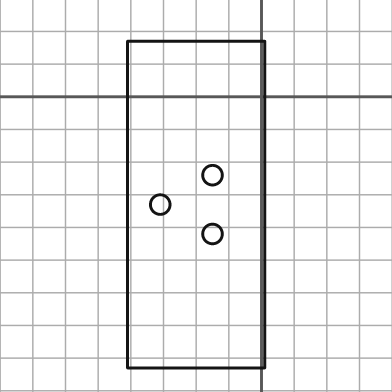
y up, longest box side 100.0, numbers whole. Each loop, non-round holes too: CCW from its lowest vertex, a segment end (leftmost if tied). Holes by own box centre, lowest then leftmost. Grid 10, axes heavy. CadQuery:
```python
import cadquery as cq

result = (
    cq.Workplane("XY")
    .moveTo(-41.0, -83.0)
    .lineTo(1.0, -83.0)
    .lineTo(1.0, 17.0)
    .lineTo(-41.0, 17.0)
    .close()
    .moveTo(-15.0, -42.0)
    .circle(3.0)
    .moveTo(-31.0, -33.0)
    .circle(3.0)
    .moveTo(-15.0, -24.0)
    .circle(3.0)
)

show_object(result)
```